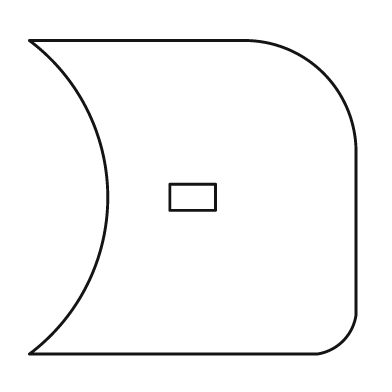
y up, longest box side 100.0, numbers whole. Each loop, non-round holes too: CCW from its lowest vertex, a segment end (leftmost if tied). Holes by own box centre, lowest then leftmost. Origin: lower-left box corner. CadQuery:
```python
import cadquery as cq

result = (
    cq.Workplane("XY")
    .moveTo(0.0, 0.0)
    .lineTo(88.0, 0.0)
    .threePointArc((96.0, 4.0), (100.0, 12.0))
    .lineTo(100.0, 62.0)
    .threePointArc((90.0, 86.0), (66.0, 96.0))
    .lineTo(0.0, 96.0)
    .threePointArc((24.0, 48.0), (0.0, 0.0))
    .close()
    .moveTo(43.0, 44.0)
    .lineTo(57.0, 44.0)
    .lineTo(57.0, 52.0)
    .lineTo(43.0, 52.0)
    .close()
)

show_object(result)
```